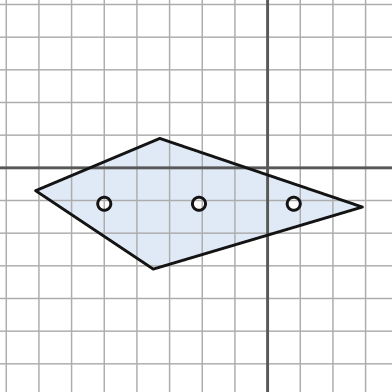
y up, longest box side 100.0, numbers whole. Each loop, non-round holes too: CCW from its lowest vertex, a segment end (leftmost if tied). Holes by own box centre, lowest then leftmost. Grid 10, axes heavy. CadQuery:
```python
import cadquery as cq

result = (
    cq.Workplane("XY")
    .moveTo(-35.0, -31.0)
    .lineTo(29.0, -12.0)
    .lineTo(-33.0, 9.0)
    .lineTo(-71.0, -7.0)
    .close()
    .moveTo(-50.0, -11.0)
    .circle(2.0)
    .moveTo(-21.0, -11.0)
    .circle(2.0)
    .moveTo(8.0, -11.0)
    .circle(2.0)
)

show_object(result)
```